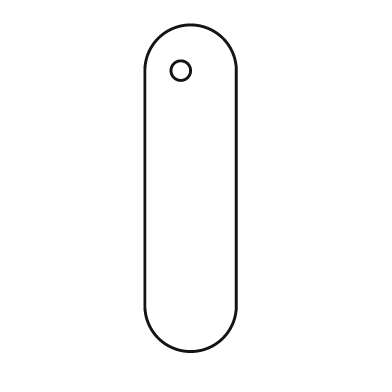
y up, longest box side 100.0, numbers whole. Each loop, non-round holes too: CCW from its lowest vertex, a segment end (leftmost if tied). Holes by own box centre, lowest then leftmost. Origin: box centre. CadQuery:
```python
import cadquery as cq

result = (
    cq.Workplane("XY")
    .moveTo(-14.0, -36.0)
    .threePointArc((0.0, -50.0), (14.0, -36.0))
    .lineTo(14.0, 36.0)
    .threePointArc((0.0, 50.0), (-14.0, 36.0))
    .close()
    .moveTo(-3.0, 36.0)
    .circle(3.0)
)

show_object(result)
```